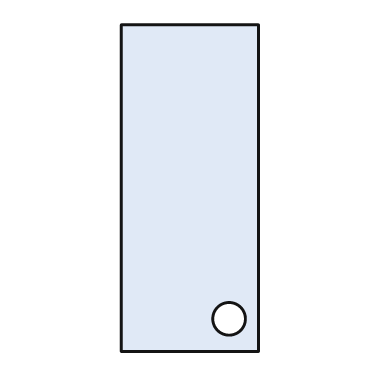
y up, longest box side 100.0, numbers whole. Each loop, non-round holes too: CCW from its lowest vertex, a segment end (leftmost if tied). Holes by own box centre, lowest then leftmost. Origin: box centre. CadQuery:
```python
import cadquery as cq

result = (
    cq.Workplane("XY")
    .moveTo(-21.0, -50.0)
    .lineTo(21.0, -50.0)
    .lineTo(21.0, 50.0)
    .lineTo(-21.0, 50.0)
    .close()
    .moveTo(12.0, -40.0)
    .circle(5.0)
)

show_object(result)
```